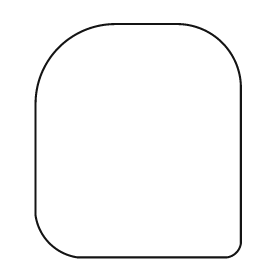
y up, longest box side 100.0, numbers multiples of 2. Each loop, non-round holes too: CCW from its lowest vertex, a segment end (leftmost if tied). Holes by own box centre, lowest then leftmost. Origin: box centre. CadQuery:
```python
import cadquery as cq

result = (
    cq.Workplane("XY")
    .moveTo(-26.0, -50.0)
    .lineTo(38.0, -50.0)
    .threePointArc((42.0, -48.0), (44.0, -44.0))
    .lineTo(44.0, 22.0)
    .threePointArc((36.0, 42.0), (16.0, 50.0))
    .lineTo(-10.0, 50.0)
    .threePointArc((-34.0, 40.0), (-44.0, 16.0))
    .lineTo(-44.0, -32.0)
    .threePointArc((-38.0, -44.0), (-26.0, -50.0))
    .close()
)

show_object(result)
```